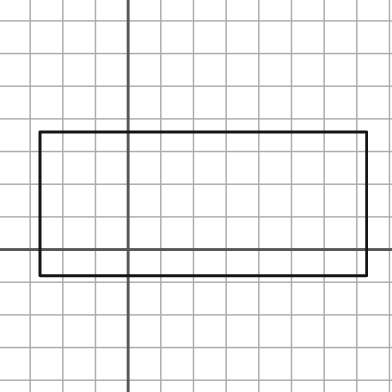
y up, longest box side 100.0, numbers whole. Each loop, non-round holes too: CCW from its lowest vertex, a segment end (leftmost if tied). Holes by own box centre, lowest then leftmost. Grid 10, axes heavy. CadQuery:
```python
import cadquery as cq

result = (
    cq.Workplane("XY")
    .moveTo(-27.0, -8.0)
    .lineTo(73.0, -8.0)
    .lineTo(73.0, 36.0)
    .lineTo(-27.0, 36.0)
    .close()
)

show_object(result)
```